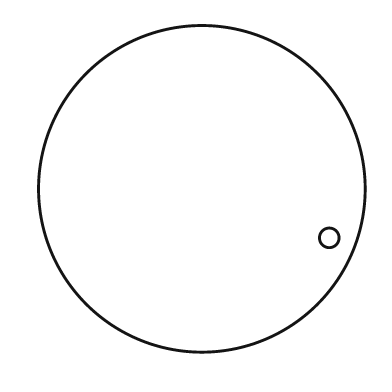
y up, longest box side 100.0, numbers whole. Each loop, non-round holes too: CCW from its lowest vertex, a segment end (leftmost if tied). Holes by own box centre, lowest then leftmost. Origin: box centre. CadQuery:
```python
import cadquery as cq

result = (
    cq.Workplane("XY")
    .moveTo(0.0, 0.0)
    .circle(50.0)
    .moveTo(39.0, -15.0)
    .circle(3.0)
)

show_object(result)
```